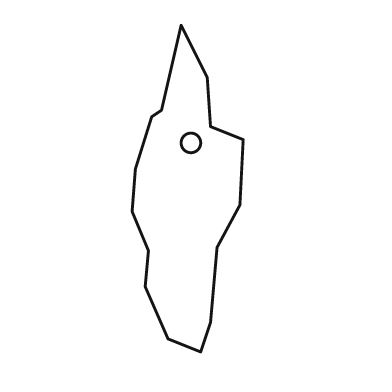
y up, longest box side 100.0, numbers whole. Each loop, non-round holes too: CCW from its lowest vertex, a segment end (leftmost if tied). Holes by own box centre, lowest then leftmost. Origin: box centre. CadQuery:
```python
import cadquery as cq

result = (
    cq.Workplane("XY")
    .moveTo(4.0, -50.0)
    .lineTo(7.0, -41.0)
    .lineTo(9.0, -18.0)
    .lineTo(16.0, -5.0)
    .lineTo(17.0, 15.0)
    .lineTo(7.0, 19.0)
    .lineTo(6.0, 34.0)
    .lineTo(-2.0, 50.0)
    .lineTo(-8.0, 24.0)
    .lineTo(-11.0, 22.0)
    .lineTo(-16.0, 6.0)
    .lineTo(-17.0, -7.0)
    .lineTo(-12.0, -19.0)
    .lineTo(-13.0, -30.0)
    .lineTo(-6.0, -46.0)
    .close()
    .moveTo(1.0, 14.0)
    .circle(3.0)
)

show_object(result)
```